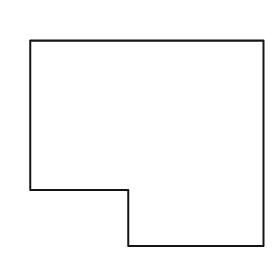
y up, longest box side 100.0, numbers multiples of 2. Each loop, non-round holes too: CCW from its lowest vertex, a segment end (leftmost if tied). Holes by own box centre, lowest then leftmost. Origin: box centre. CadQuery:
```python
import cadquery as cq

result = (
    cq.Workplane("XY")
    .moveTo(-8.0, -44.0)
    .lineTo(50.0, -44.0)
    .lineTo(50.0, 44.0)
    .lineTo(-50.0, 44.0)
    .lineTo(-50.0, -20.0)
    .lineTo(-8.0, -20.0)
    .close()
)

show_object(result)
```